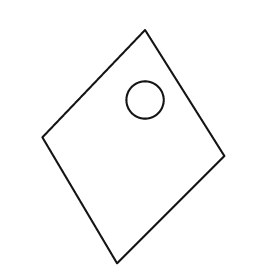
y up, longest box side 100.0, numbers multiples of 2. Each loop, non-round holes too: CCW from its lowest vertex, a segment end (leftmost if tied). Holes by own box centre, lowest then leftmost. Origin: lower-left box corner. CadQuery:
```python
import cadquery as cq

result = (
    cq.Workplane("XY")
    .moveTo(32.0, 0.0)
    .lineTo(78.0, 46.0)
    .lineTo(44.0, 100.0)
    .lineTo(0.0, 54.0)
    .close()
    .moveTo(44.0, 70.0)
    .circle(8.0)
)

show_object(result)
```